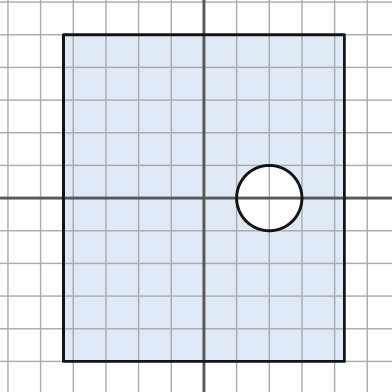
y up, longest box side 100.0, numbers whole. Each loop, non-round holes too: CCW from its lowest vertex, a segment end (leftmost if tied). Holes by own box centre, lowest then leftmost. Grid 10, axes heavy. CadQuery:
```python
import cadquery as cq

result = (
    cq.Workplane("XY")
    .moveTo(-43.0, -50.0)
    .lineTo(43.0, -50.0)
    .lineTo(43.0, 50.0)
    .lineTo(-43.0, 50.0)
    .close()
    .moveTo(20.0, 0.0)
    .circle(10.0)
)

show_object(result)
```